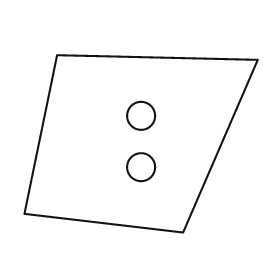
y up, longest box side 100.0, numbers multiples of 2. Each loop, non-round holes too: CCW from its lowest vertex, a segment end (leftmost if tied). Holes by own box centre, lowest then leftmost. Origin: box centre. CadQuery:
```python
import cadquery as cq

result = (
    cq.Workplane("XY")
    .moveTo(18.0, -38.0)
    .lineTo(50.0, 36.0)
    .lineTo(-36.0, 38.0)
    .lineTo(-50.0, -30.0)
    .close()
    .moveTo(0.0, -10.0)
    .circle(6.0)
    .moveTo(0.0, 12.0)
    .circle(6.0)
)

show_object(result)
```